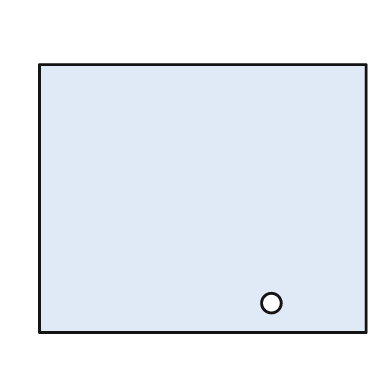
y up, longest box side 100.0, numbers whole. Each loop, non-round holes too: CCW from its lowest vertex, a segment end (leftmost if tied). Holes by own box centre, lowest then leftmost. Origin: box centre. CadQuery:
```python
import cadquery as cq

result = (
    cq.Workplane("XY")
    .moveTo(-50.0, -41.0)
    .lineTo(50.0, -41.0)
    .lineTo(50.0, 41.0)
    .lineTo(-50.0, 41.0)
    .close()
    .moveTo(21.0, -32.0)
    .circle(3.0)
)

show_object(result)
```